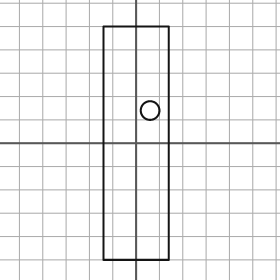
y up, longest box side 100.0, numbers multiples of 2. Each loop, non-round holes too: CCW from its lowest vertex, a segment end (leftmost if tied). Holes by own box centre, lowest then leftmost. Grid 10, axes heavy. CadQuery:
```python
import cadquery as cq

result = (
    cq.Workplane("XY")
    .moveTo(-14.0, -50.0)
    .lineTo(14.0, -50.0)
    .lineTo(14.0, 50.0)
    .lineTo(-14.0, 50.0)
    .close()
    .moveTo(6.0, 14.0)
    .circle(4.0)
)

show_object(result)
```